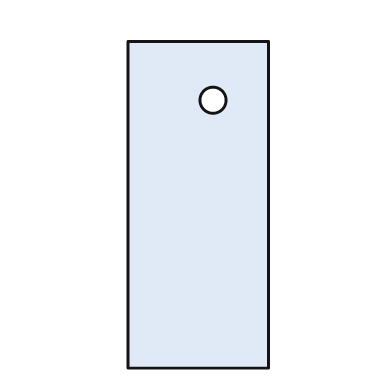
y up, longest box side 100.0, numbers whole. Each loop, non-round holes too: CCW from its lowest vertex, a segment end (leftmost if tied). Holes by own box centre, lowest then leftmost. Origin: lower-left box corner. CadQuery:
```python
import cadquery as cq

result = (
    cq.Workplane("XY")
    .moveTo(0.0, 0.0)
    .lineTo(43.0, 0.0)
    .lineTo(43.0, 100.0)
    .lineTo(0.0, 100.0)
    .close()
    .moveTo(26.0, 82.0)
    .circle(4.0)
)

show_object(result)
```